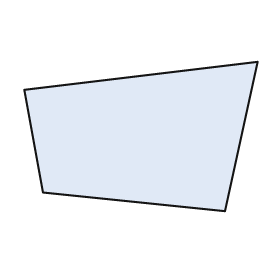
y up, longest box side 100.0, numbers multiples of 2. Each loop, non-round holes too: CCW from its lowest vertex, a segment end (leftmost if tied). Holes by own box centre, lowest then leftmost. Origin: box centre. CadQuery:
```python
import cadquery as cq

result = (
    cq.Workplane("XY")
    .moveTo(36.0, -32.0)
    .lineTo(50.0, 32.0)
    .lineTo(-50.0, 20.0)
    .lineTo(-42.0, -24.0)
    .close()
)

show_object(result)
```